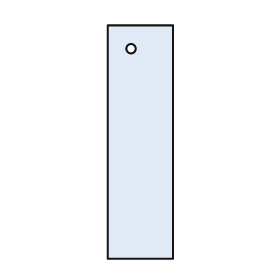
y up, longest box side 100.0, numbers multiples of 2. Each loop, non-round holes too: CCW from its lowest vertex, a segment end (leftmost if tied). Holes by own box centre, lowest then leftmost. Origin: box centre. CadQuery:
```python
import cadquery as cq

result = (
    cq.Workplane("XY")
    .moveTo(-14.0, -50.0)
    .lineTo(14.0, -50.0)
    .lineTo(14.0, 50.0)
    .lineTo(-14.0, 50.0)
    .close()
    .moveTo(-4.0, 40.0)
    .circle(2.0)
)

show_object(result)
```